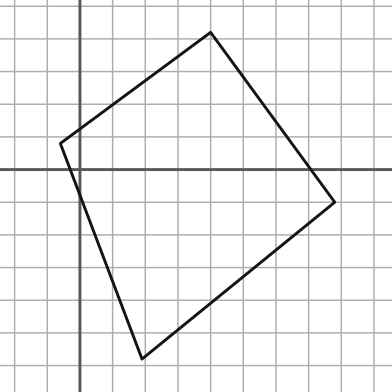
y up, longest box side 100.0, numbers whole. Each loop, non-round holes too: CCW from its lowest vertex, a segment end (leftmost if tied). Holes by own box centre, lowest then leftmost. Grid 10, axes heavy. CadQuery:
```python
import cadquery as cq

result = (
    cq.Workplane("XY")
    .moveTo(19.0, -58.0)
    .lineTo(78.0, -10.0)
    .lineTo(40.0, 42.0)
    .lineTo(-6.0, 8.0)
    .close()
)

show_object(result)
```